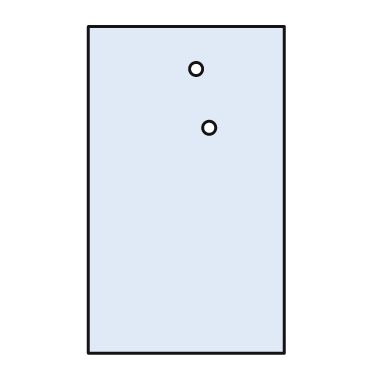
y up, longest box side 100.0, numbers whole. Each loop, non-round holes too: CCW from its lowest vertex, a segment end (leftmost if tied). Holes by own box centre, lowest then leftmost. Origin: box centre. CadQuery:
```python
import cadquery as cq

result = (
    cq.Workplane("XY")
    .moveTo(-30.0, -50.0)
    .lineTo(30.0, -50.0)
    .lineTo(30.0, 50.0)
    .lineTo(-30.0, 50.0)
    .close()
    .moveTo(7.0, 19.0)
    .circle(2.0)
    .moveTo(3.0, 37.0)
    .circle(2.0)
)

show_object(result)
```